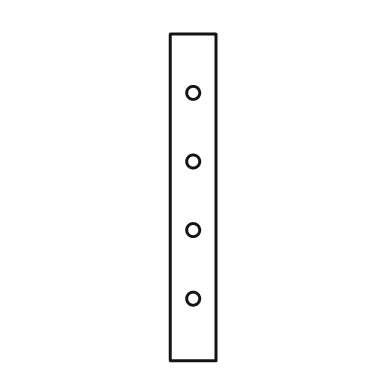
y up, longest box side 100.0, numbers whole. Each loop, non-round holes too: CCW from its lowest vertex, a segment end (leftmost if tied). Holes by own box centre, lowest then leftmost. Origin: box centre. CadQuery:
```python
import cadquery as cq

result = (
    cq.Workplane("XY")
    .moveTo(-7.0, -50.0)
    .lineTo(7.0, -50.0)
    .lineTo(7.0, 50.0)
    .lineTo(-7.0, 50.0)
    .close()
    .moveTo(0.0, -31.0)
    .circle(2.0)
    .moveTo(0.0, -10.0)
    .circle(2.0)
    .moveTo(0.0, 11.0)
    .circle(2.0)
    .moveTo(0.0, 32.0)
    .circle(2.0)
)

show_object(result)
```